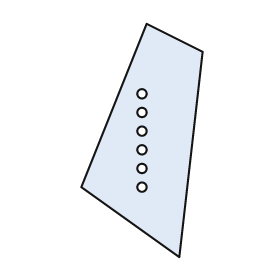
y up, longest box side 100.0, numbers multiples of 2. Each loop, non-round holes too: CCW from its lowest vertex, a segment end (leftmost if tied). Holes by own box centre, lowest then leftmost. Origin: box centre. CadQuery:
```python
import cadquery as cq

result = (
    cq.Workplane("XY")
    .moveTo(16.0, -50.0)
    .lineTo(26.0, 38.0)
    .lineTo(2.0, 50.0)
    .lineTo(-26.0, -20.0)
    .close()
    .moveTo(0.0, -20.0)
    .circle(2.0)
    .moveTo(0.0, -12.0)
    .circle(2.0)
    .moveTo(0.0, -4.0)
    .circle(2.0)
    .moveTo(0.0, 4.0)
    .circle(2.0)
    .moveTo(0.0, 12.0)
    .circle(2.0)
    .moveTo(0.0, 20.0)
    .circle(2.0)
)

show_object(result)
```